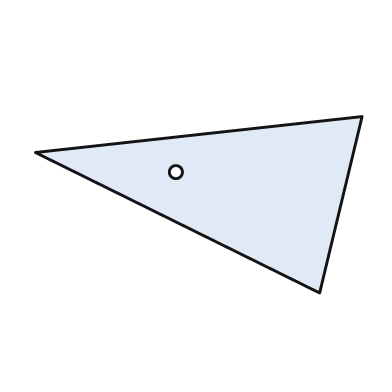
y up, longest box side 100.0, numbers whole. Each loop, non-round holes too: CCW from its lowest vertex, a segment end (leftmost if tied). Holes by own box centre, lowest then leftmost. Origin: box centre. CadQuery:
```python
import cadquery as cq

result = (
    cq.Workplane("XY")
    .moveTo(37.0, -27.0)
    .lineTo(50.0, 27.0)
    .lineTo(-50.0, 16.0)
    .close()
    .moveTo(-7.0, 10.0)
    .circle(2.0)
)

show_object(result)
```